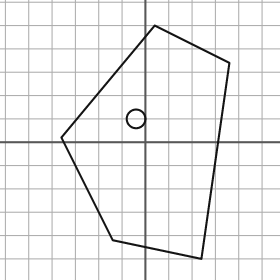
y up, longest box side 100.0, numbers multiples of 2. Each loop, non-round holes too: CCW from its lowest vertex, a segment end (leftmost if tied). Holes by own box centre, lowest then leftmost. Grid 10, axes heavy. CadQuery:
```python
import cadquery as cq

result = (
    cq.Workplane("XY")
    .moveTo(24.0, -50.0)
    .lineTo(36.0, 34.0)
    .lineTo(4.0, 50.0)
    .lineTo(-36.0, 2.0)
    .lineTo(-14.0, -42.0)
    .close()
    .moveTo(-4.0, 10.0)
    .circle(4.0)
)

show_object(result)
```